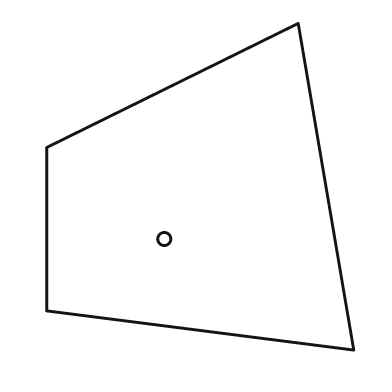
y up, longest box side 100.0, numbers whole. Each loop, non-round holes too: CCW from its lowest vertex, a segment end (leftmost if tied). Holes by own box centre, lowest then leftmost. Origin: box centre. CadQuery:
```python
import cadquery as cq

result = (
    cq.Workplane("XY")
    .moveTo(47.0, -50.0)
    .lineTo(30.0, 50.0)
    .lineTo(-47.0, 12.0)
    .lineTo(-47.0, -38.0)
    .close()
    .moveTo(-11.0, -16.0)
    .circle(2.0)
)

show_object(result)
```